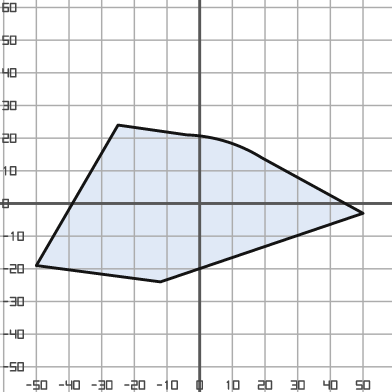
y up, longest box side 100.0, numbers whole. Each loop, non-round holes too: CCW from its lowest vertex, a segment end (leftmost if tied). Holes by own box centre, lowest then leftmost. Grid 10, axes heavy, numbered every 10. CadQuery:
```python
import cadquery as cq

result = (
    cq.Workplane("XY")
    .moveTo(-12.0, -24.0)
    .lineTo(50.0, -3.0)
    .lineTo(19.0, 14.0)
    .threePointArc((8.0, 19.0), (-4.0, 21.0))
    .lineTo(-25.0, 24.0)
    .lineTo(-50.0, -19.0)
    .close()
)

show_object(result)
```